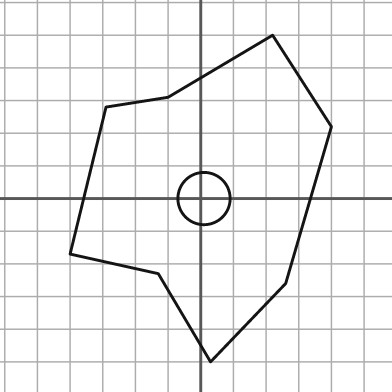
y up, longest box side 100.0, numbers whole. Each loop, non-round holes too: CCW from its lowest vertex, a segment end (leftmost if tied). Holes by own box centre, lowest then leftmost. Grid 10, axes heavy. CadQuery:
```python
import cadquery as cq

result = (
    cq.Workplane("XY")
    .moveTo(3.0, -50.0)
    .lineTo(26.0, -26.0)
    .lineTo(40.0, 22.0)
    .lineTo(22.0, 50.0)
    .lineTo(-10.0, 31.0)
    .lineTo(-29.0, 28.0)
    .lineTo(-40.0, -17.0)
    .lineTo(-13.0, -23.0)
    .close()
    .moveTo(1.0, 0.0)
    .circle(8.0)
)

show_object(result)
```